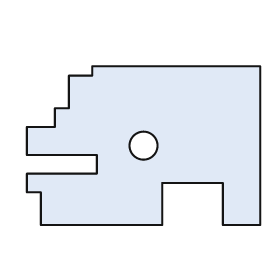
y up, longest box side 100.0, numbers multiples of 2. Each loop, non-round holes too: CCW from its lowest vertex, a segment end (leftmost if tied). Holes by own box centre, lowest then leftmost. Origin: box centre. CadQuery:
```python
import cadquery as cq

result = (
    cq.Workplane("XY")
    .moveTo(-44.0, -34.0)
    .lineTo(8.0, -34.0)
    .lineTo(8.0, -16.0)
    .lineTo(34.0, -16.0)
    .lineTo(34.0, -34.0)
    .lineTo(50.0, -34.0)
    .lineTo(50.0, 34.0)
    .lineTo(-22.0, 34.0)
    .lineTo(-22.0, 30.0)
    .lineTo(-32.0, 30.0)
    .lineTo(-32.0, 16.0)
    .lineTo(-38.0, 16.0)
    .lineTo(-38.0, 8.0)
    .lineTo(-50.0, 8.0)
    .lineTo(-50.0, -4.0)
    .lineTo(-20.0, -4.0)
    .lineTo(-20.0, -12.0)
    .lineTo(-50.0, -12.0)
    .lineTo(-50.0, -20.0)
    .lineTo(-44.0, -20.0)
    .close()
    .moveTo(0.0, 0.0)
    .circle(6.0)
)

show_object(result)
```